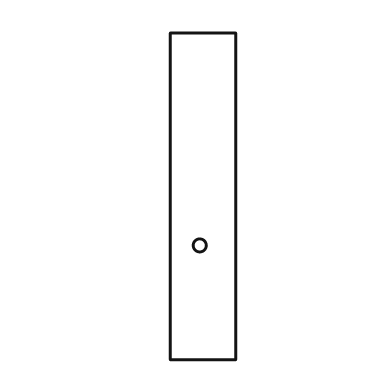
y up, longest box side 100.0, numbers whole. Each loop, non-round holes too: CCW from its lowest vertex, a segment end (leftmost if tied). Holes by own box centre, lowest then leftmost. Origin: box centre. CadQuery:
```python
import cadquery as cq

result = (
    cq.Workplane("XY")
    .moveTo(-10.0, -50.0)
    .lineTo(10.0, -50.0)
    .lineTo(10.0, 50.0)
    .lineTo(-10.0, 50.0)
    .close()
    .moveTo(-1.0, -15.0)
    .circle(2.0)
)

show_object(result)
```